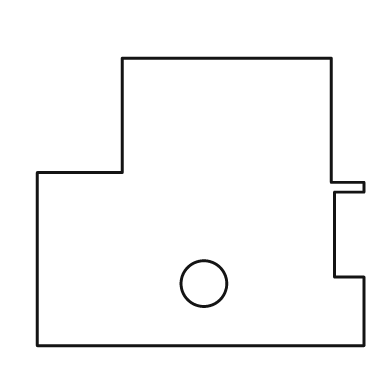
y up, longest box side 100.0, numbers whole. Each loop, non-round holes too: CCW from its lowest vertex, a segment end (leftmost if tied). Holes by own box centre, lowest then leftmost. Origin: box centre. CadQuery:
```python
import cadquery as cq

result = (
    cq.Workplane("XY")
    .moveTo(-50.0, -44.0)
    .lineTo(50.0, -44.0)
    .lineTo(50.0, -23.0)
    .lineTo(41.0, -23.0)
    .lineTo(41.0, 3.0)
    .lineTo(50.0, 3.0)
    .lineTo(50.0, 6.0)
    .lineTo(40.0, 6.0)
    .lineTo(40.0, 44.0)
    .lineTo(-24.0, 44.0)
    .lineTo(-24.0, 9.0)
    .lineTo(-50.0, 9.0)
    .close()
    .moveTo(1.0, -25.0)
    .circle(7.0)
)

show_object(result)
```